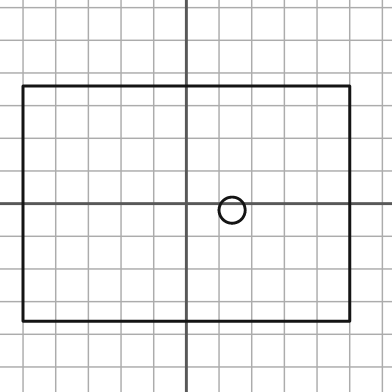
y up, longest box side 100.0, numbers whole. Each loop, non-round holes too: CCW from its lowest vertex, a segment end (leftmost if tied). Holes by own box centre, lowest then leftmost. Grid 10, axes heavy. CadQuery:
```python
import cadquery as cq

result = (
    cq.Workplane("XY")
    .moveTo(-50.0, -36.0)
    .lineTo(50.0, -36.0)
    .lineTo(50.0, 36.0)
    .lineTo(-50.0, 36.0)
    .close()
    .moveTo(14.0, -2.0)
    .circle(4.0)
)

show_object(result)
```